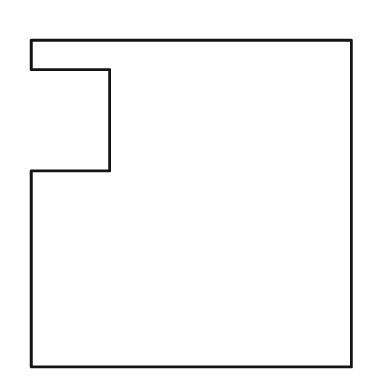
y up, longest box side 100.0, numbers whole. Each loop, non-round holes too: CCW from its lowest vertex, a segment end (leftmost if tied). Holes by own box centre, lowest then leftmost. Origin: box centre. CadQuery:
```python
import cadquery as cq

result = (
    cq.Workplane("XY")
    .moveTo(-49.0, -50.0)
    .lineTo(49.0, -50.0)
    .lineTo(49.0, 50.0)
    .lineTo(-49.0, 50.0)
    .lineTo(-49.0, 41.0)
    .lineTo(-25.0, 41.0)
    .lineTo(-25.0, 10.0)
    .lineTo(-49.0, 10.0)
    .close()
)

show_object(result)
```